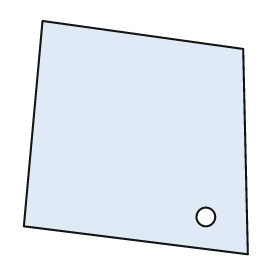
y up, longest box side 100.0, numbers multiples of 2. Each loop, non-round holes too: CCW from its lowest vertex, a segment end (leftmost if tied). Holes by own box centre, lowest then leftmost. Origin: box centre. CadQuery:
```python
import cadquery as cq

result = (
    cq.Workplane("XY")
    .moveTo(48.0, -50.0)
    .lineTo(46.0, 38.0)
    .lineTo(-40.0, 50.0)
    .lineTo(-48.0, -38.0)
    .close()
    .moveTo(30.0, -34.0)
    .circle(4.0)
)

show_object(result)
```